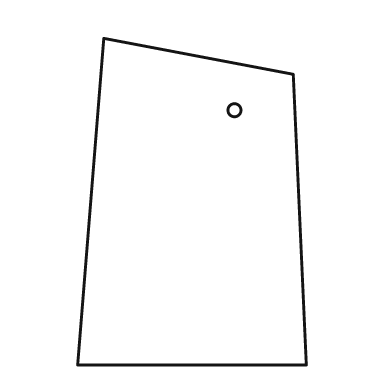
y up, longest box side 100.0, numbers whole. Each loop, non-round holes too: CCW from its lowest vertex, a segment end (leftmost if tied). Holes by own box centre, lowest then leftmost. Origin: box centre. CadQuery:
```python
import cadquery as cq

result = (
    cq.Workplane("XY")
    .moveTo(-35.0, -50.0)
    .lineTo(35.0, -50.0)
    .lineTo(31.0, 39.0)
    .lineTo(-27.0, 50.0)
    .close()
    .moveTo(13.0, 28.0)
    .circle(2.0)
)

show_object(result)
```